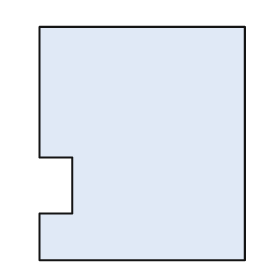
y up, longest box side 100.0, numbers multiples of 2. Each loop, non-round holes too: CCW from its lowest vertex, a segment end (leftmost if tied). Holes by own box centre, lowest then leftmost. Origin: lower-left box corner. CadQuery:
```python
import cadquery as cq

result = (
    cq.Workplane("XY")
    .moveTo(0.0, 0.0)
    .lineTo(88.0, 0.0)
    .lineTo(88.0, 100.0)
    .lineTo(0.0, 100.0)
    .lineTo(0.0, 44.0)
    .lineTo(14.0, 44.0)
    .lineTo(14.0, 20.0)
    .lineTo(0.0, 20.0)
    .close()
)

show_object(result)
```